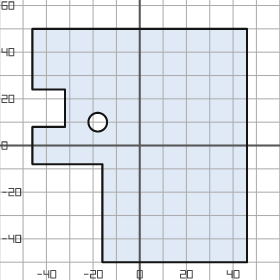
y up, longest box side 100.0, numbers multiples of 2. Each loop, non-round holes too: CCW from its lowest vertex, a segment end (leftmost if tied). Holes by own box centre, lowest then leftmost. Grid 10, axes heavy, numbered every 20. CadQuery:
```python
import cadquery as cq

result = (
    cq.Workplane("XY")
    .moveTo(-16.0, -50.0)
    .lineTo(46.0, -50.0)
    .lineTo(46.0, 50.0)
    .lineTo(-46.0, 50.0)
    .lineTo(-46.0, 24.0)
    .lineTo(-32.0, 24.0)
    .lineTo(-32.0, 8.0)
    .lineTo(-46.0, 8.0)
    .lineTo(-46.0, -8.0)
    .lineTo(-16.0, -8.0)
    .close()
    .moveTo(-18.0, 10.0)
    .circle(4.0)
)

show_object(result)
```